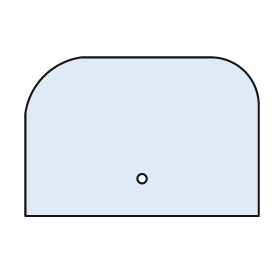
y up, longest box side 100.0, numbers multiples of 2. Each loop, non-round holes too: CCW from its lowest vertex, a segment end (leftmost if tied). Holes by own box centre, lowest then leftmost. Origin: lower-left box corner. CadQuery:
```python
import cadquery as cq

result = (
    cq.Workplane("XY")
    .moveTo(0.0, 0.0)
    .lineTo(100.0, 0.0)
    .lineTo(100.0, 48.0)
    .threePointArc((94.0, 62.0), (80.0, 68.0))
    .lineTo(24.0, 68.0)
    .threePointArc((8.0, 60.0), (0.0, 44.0))
    .close()
    .moveTo(50.0, 16.0)
    .circle(2.0)
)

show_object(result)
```